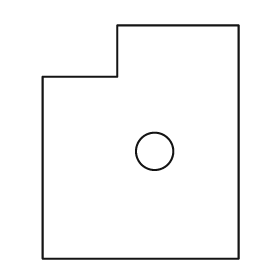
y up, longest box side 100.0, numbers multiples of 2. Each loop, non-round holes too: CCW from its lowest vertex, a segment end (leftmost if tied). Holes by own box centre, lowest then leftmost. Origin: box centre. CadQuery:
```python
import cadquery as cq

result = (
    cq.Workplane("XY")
    .moveTo(-42.0, -50.0)
    .lineTo(42.0, -50.0)
    .lineTo(42.0, 50.0)
    .lineTo(-10.0, 50.0)
    .lineTo(-10.0, 28.0)
    .lineTo(-42.0, 28.0)
    .close()
    .moveTo(6.0, -4.0)
    .circle(8.0)
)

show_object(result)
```